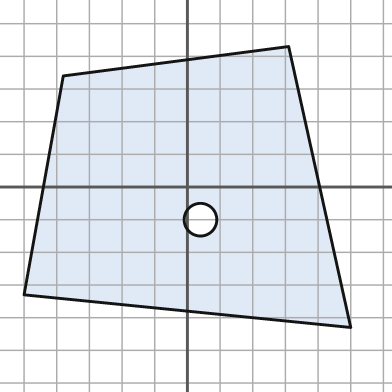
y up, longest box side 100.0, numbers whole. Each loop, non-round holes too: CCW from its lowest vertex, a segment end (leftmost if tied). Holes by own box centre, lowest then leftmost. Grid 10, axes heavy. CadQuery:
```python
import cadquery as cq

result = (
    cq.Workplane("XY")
    .moveTo(50.0, -43.0)
    .lineTo(31.0, 43.0)
    .lineTo(-38.0, 34.0)
    .lineTo(-50.0, -33.0)
    .close()
    .moveTo(4.0, -10.0)
    .circle(5.0)
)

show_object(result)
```